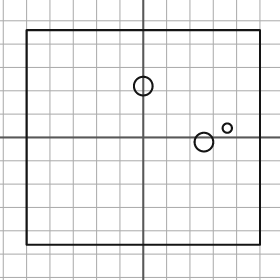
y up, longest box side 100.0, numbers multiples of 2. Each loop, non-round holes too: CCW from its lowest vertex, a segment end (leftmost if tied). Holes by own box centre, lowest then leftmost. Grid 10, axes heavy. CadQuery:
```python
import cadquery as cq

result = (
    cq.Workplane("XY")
    .moveTo(-50.0, -46.0)
    .lineTo(50.0, -46.0)
    .lineTo(50.0, 46.0)
    .lineTo(-50.0, 46.0)
    .close()
    .moveTo(26.0, -2.0)
    .circle(4.0)
    .moveTo(36.0, 4.0)
    .circle(2.0)
    .moveTo(0.0, 22.0)
    .circle(4.0)
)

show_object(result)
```